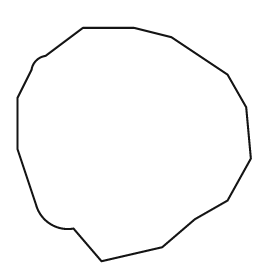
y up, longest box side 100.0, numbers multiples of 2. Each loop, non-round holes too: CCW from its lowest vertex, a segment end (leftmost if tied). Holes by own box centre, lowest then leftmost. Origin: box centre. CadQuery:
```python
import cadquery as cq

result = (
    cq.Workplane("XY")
    .moveTo(-14.0, -50.0)
    .lineTo(12.0, -44.0)
    .lineTo(26.0, -32.0)
    .lineTo(40.0, -24.0)
    .lineTo(50.0, -6.0)
    .lineTo(48.0, 16.0)
    .lineTo(40.0, 30.0)
    .lineTo(16.0, 46.0)
    .lineTo(0.0, 50.0)
    .lineTo(-22.0, 50.0)
    .lineTo(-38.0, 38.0)
    .threePointArc((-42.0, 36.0), (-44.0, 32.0))
    .lineTo(-50.0, 20.0)
    .lineTo(-50.0, -2.0)
    .lineTo(-42.0, -26.0)
    .threePointArc((-36.0, -34.0), (-26.0, -36.0))
    .close()
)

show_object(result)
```